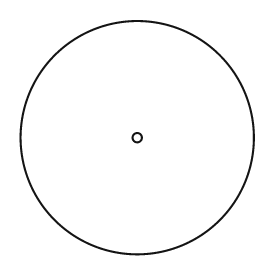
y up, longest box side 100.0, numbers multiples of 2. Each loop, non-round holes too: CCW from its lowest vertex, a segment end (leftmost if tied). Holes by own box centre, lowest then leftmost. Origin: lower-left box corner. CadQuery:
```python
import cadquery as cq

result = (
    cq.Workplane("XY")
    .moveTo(50.0, 50.0)
    .circle(50.0)
    .moveTo(50.0, 50.0)
    .circle(2.0)
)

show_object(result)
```